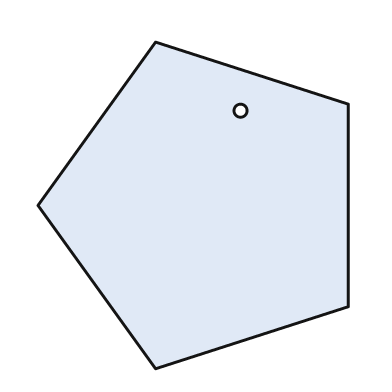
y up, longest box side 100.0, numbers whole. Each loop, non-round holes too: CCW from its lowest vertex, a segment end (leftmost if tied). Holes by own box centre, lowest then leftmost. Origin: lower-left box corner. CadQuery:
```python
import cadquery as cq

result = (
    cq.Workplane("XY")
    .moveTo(36.0, 0.0)
    .lineTo(95.0, 19.0)
    .lineTo(95.0, 81.0)
    .lineTo(36.0, 100.0)
    .lineTo(0.0, 50.0)
    .close()
    .moveTo(62.0, 79.0)
    .circle(2.0)
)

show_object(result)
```